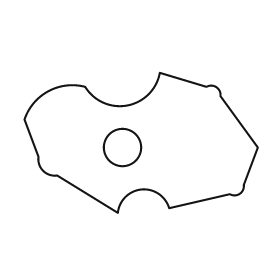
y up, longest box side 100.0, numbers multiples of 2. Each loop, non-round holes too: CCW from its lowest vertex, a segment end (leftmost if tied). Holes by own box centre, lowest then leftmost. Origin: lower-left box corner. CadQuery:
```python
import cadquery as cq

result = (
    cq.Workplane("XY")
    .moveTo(40.0, 0.0)
    .threePointArc((50.0, 10.0), (62.0, 2.0))
    .lineTo(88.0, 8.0)
    .threePointArc((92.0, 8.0), (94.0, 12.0))
    .lineTo(100.0, 28.0)
    .lineTo(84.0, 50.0)
    .threePointArc((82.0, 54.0), (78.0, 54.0))
    .lineTo(58.0, 60.0)
    .threePointArc((44.0, 46.0), (26.0, 54.0))
    .threePointArc((10.0, 52.0), (0.0, 40.0))
    .lineTo(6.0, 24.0)
    .threePointArc((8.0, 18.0), (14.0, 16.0))
    .close()
    .moveTo(42.0, 28.0)
    .circle(8.0)
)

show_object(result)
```